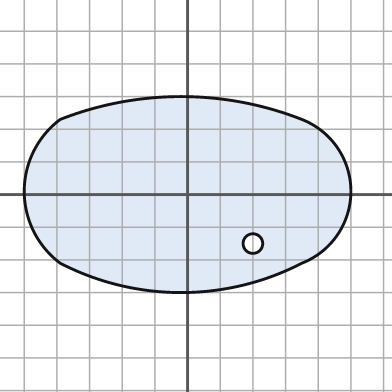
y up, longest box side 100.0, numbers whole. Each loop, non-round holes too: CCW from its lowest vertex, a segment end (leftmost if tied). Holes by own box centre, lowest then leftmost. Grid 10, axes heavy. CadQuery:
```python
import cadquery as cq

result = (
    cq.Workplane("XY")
    .moveTo(-39.0, -21.0)
    .threePointArc((-2.0, -30.0), (35.0, -21.0))
    .threePointArc((50.0, 1.0), (35.0, 23.0))
    .threePointArc((-2.0, 30.0), (-39.0, 23.0))
    .threePointArc((-50.0, 1.0), (-39.0, -21.0))
    .close()
    .moveTo(20.0, -15.0)
    .circle(3.0)
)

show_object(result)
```